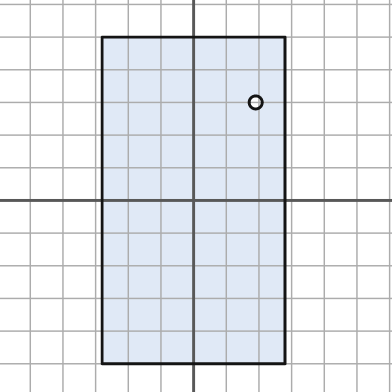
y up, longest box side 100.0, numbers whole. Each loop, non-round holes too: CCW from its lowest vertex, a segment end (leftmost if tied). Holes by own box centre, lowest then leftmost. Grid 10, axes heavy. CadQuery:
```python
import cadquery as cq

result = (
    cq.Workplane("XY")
    .moveTo(-28.0, -50.0)
    .lineTo(28.0, -50.0)
    .lineTo(28.0, 50.0)
    .lineTo(-28.0, 50.0)
    .close()
    .moveTo(19.0, 30.0)
    .circle(2.0)
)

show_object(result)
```